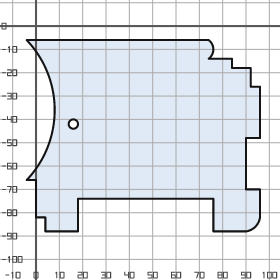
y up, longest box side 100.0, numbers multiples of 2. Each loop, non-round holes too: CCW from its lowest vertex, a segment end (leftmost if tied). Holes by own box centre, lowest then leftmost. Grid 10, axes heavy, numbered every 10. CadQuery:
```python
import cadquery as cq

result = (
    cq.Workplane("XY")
    .moveTo(4.0, -88.0)
    .lineTo(18.0, -88.0)
    .lineTo(18.0, -74.0)
    .lineTo(76.0, -74.0)
    .lineTo(76.0, -88.0)
    .lineTo(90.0, -88.0)
    .threePointArc((94.0, -86.0), (96.0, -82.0))
    .lineTo(96.0, -70.0)
    .lineTo(90.0, -70.0)
    .lineTo(90.0, -48.0)
    .lineTo(96.0, -48.0)
    .lineTo(96.0, -26.0)
    .lineTo(92.0, -26.0)
    .lineTo(92.0, -18.0)
    .lineTo(84.0, -18.0)
    .lineTo(84.0, -14.0)
    .lineTo(74.0, -14.0)
    .threePointArc((76.0, -10.0), (74.0, -6.0))
    .lineTo(-4.0, -6.0)
    .threePointArc((8.0, -36.0), (-4.0, -66.0))
    .lineTo(0.0, -66.0)
    .lineTo(0.0, -82.0)
    .lineTo(4.0, -82.0)
    .close()
    .moveTo(16.0, -42.0)
    .circle(2.0)
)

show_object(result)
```